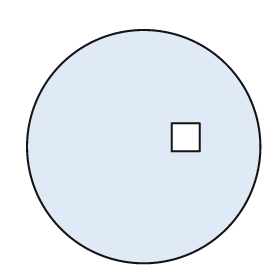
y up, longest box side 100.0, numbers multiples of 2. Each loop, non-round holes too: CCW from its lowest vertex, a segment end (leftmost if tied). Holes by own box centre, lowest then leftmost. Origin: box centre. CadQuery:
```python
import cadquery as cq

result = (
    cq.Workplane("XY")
    .moveTo(0.0, 0.0)
    .circle(50.0)
    .moveTo(12.0, -2.0)
    .lineTo(24.0, -2.0)
    .lineTo(24.0, 10.0)
    .lineTo(12.0, 10.0)
    .close()
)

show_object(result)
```